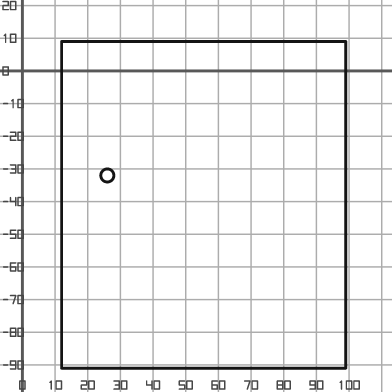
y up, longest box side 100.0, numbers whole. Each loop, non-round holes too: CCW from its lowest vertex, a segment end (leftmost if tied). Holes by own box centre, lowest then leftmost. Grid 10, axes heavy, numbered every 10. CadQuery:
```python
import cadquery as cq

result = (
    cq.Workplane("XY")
    .moveTo(12.0, -91.0)
    .lineTo(99.0, -91.0)
    .lineTo(99.0, 9.0)
    .lineTo(12.0, 9.0)
    .close()
    .moveTo(26.0, -32.0)
    .circle(2.0)
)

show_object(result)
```